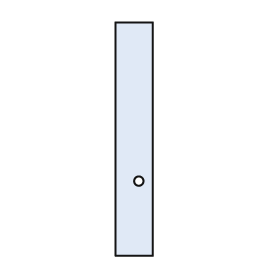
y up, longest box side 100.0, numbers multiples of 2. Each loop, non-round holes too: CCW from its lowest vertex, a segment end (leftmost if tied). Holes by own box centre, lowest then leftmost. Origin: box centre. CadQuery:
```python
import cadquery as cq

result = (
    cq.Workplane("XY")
    .moveTo(-8.0, -50.0)
    .lineTo(8.0, -50.0)
    .lineTo(8.0, 50.0)
    .lineTo(-8.0, 50.0)
    .close()
    .moveTo(2.0, -18.0)
    .circle(2.0)
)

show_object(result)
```